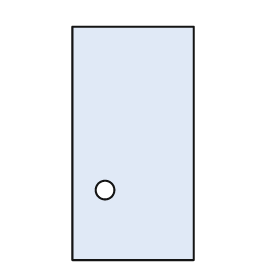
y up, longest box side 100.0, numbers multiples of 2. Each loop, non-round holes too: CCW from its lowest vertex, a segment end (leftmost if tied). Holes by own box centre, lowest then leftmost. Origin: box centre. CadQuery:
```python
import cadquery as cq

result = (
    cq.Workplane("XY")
    .moveTo(-26.0, -50.0)
    .lineTo(26.0, -50.0)
    .lineTo(26.0, 50.0)
    .lineTo(-26.0, 50.0)
    .close()
    .moveTo(-12.0, -20.0)
    .circle(4.0)
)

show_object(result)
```